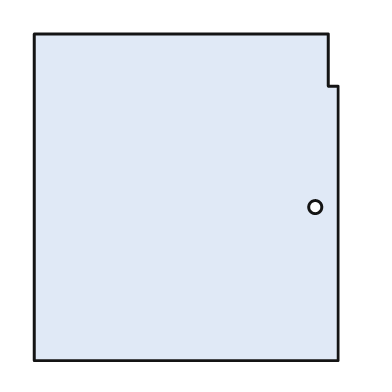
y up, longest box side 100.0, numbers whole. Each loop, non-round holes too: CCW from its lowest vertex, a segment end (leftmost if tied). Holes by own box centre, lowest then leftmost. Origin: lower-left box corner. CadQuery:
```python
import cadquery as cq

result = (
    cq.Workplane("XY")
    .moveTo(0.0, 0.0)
    .lineTo(93.0, 0.0)
    .lineTo(93.0, 84.0)
    .lineTo(90.0, 84.0)
    .lineTo(90.0, 100.0)
    .lineTo(0.0, 100.0)
    .close()
    .moveTo(86.0, 47.0)
    .circle(2.0)
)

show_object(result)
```